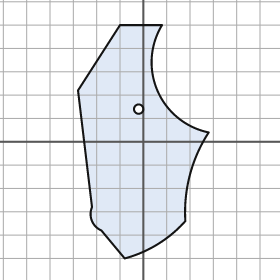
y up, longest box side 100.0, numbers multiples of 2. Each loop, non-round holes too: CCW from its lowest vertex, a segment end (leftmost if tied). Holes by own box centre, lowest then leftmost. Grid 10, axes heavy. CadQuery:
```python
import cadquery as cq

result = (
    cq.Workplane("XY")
    .moveTo(-8.0, -50.0)
    .threePointArc((6.0, -44.0), (18.0, -34.0))
    .threePointArc((20.0, -14.0), (28.0, 4.0))
    .threePointArc((6.0, 22.0), (8.0, 50.0))
    .lineTo(-10.0, 50.0)
    .lineTo(-28.0, 22.0)
    .lineTo(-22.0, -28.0)
    .threePointArc((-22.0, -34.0), (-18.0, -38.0))
    .close()
    .moveTo(-2.0, 14.0)
    .circle(2.0)
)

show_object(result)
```